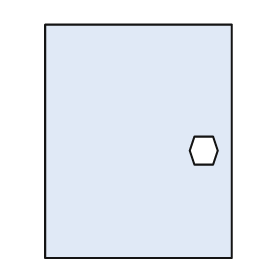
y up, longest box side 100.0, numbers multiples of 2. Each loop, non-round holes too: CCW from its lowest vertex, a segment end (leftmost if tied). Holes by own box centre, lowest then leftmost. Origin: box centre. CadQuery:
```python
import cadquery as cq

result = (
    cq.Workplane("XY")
    .moveTo(-40.0, -50.0)
    .lineTo(40.0, -50.0)
    .lineTo(40.0, 50.0)
    .lineTo(-40.0, 50.0)
    .close()
    .moveTo(24.0, -10.0)
    .lineTo(32.0, -10.0)
    .lineTo(34.0, -4.0)
    .lineTo(32.0, 2.0)
    .lineTo(24.0, 2.0)
    .lineTo(22.0, -4.0)
    .close()
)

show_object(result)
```